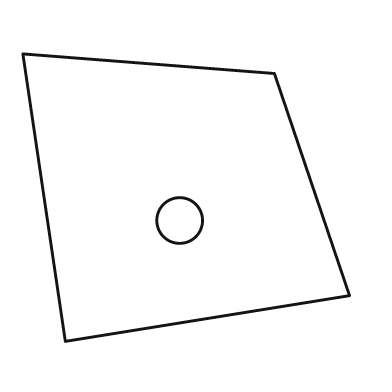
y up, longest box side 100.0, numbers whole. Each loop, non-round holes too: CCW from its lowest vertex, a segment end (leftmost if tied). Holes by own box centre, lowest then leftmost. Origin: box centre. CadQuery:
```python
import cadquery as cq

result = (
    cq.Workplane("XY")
    .moveTo(-37.0, -44.0)
    .lineTo(50.0, -30.0)
    .lineTo(27.0, 38.0)
    .lineTo(-50.0, 44.0)
    .close()
    .moveTo(-2.0, -7.0)
    .circle(7.0)
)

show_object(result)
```